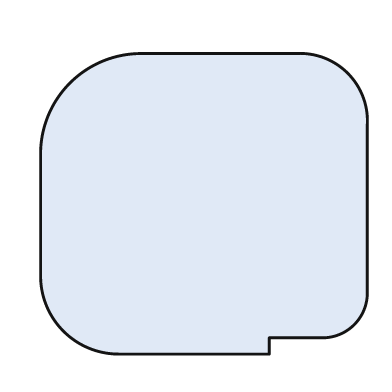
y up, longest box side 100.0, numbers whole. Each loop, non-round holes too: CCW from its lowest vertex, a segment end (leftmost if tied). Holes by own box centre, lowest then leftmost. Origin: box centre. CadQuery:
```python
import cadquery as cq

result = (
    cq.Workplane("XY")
    .moveTo(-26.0, -46.0)
    .lineTo(20.0, -46.0)
    .lineTo(20.0, -41.0)
    .lineTo(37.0, -41.0)
    .threePointArc((46.0, -37.0), (50.0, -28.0))
    .lineTo(50.0, 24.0)
    .threePointArc((44.0, 40.0), (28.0, 46.0))
    .lineTo(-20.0, 46.0)
    .threePointArc((-41.0, 37.0), (-50.0, 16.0))
    .lineTo(-50.0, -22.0)
    .threePointArc((-43.0, -39.0), (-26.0, -46.0))
    .close()
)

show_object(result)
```